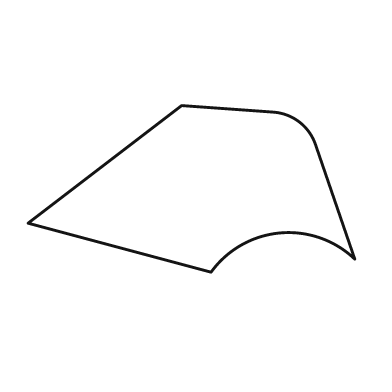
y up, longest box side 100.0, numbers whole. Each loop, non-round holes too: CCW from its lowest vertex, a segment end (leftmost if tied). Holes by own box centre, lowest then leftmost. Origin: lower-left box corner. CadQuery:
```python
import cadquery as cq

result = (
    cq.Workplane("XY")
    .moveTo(56.0, 0.0)
    .threePointArc((77.0, 12.0), (100.0, 4.0))
    .lineTo(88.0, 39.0)
    .threePointArc((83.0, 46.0), (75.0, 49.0))
    .lineTo(47.0, 51.0)
    .lineTo(0.0, 15.0)
    .close()
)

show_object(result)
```